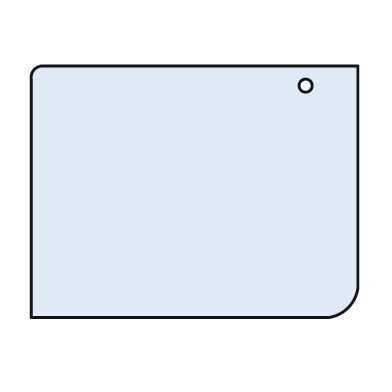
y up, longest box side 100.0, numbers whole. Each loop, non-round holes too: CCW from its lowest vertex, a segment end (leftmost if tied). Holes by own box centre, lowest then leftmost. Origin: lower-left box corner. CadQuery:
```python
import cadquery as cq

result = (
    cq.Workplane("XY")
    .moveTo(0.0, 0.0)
    .lineTo(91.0, 0.0)
    .threePointArc((97.0, 3.0), (100.0, 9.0))
    .lineTo(100.0, 77.0)
    .lineTo(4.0, 77.0)
    .threePointArc((1.0, 76.0), (0.0, 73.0))
    .close()
    .moveTo(84.0, 71.0)
    .circle(2.0)
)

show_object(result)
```